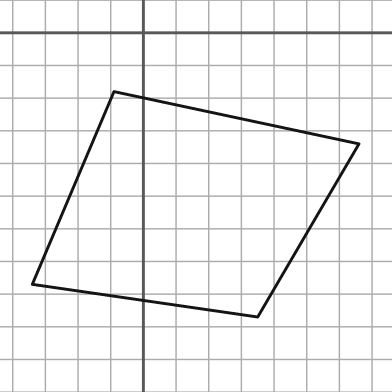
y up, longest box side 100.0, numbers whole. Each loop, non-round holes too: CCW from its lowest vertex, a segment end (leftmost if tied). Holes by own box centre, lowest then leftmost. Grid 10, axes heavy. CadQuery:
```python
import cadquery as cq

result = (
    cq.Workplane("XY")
    .moveTo(35.0, -87.0)
    .lineTo(66.0, -34.0)
    .lineTo(-9.0, -18.0)
    .lineTo(-34.0, -77.0)
    .close()
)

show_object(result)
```